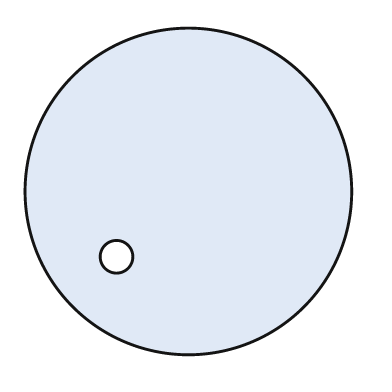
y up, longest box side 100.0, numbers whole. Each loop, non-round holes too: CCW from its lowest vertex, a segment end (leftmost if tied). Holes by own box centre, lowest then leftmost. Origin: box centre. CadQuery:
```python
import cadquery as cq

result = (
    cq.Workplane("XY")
    .moveTo(0.0, 0.0)
    .circle(50.0)
    .moveTo(-22.0, -20.0)
    .circle(5.0)
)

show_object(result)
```